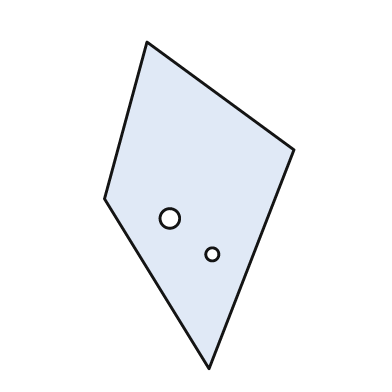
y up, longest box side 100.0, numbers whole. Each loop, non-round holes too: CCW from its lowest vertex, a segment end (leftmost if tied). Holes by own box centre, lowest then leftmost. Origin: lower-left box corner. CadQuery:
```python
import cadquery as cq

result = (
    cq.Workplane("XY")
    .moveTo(32.0, 0.0)
    .lineTo(58.0, 67.0)
    .lineTo(13.0, 100.0)
    .lineTo(0.0, 52.0)
    .close()
    .moveTo(33.0, 35.0)
    .circle(2.0)
    .moveTo(20.0, 46.0)
    .circle(3.0)
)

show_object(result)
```